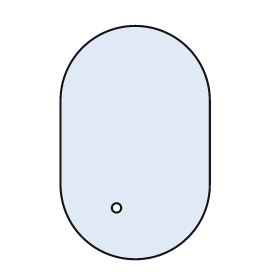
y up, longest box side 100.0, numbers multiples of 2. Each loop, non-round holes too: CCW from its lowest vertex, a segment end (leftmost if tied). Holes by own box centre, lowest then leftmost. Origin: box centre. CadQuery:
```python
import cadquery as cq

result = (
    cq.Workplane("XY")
    .moveTo(-32.0, -18.0)
    .threePointArc((0.0, -50.0), (32.0, -18.0))
    .lineTo(32.0, 18.0)
    .threePointArc((0.0, 50.0), (-32.0, 18.0))
    .close()
    .moveTo(-8.0, -28.0)
    .circle(2.0)
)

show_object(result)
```